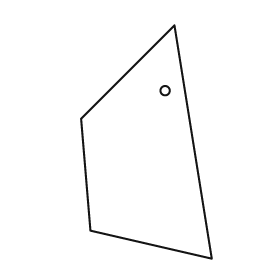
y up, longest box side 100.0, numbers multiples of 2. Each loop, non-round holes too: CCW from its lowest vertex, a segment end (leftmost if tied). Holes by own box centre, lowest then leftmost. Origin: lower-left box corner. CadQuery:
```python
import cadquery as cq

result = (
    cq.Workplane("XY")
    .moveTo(56.0, 0.0)
    .lineTo(40.0, 100.0)
    .lineTo(0.0, 60.0)
    .lineTo(4.0, 12.0)
    .close()
    .moveTo(36.0, 72.0)
    .circle(2.0)
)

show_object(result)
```